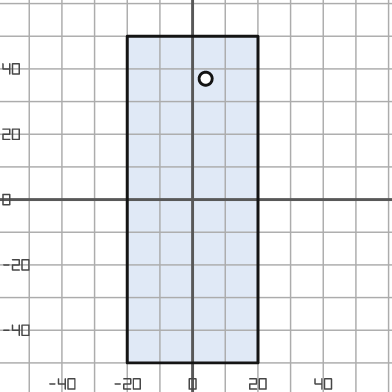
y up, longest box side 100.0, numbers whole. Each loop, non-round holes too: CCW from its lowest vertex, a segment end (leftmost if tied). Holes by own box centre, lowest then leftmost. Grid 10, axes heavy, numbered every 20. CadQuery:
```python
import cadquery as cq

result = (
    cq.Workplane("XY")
    .moveTo(-20.0, -50.0)
    .lineTo(20.0, -50.0)
    .lineTo(20.0, 50.0)
    .lineTo(-20.0, 50.0)
    .close()
    .moveTo(4.0, 37.0)
    .circle(2.0)
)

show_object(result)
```